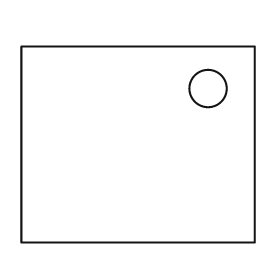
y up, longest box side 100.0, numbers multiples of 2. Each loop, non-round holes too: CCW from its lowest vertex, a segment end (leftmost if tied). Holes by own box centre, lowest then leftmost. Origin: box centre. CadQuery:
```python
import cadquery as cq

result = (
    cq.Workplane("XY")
    .moveTo(-50.0, -42.0)
    .lineTo(50.0, -42.0)
    .lineTo(50.0, 42.0)
    .lineTo(-50.0, 42.0)
    .close()
    .moveTo(30.0, 24.0)
    .circle(8.0)
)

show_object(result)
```